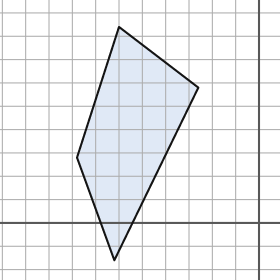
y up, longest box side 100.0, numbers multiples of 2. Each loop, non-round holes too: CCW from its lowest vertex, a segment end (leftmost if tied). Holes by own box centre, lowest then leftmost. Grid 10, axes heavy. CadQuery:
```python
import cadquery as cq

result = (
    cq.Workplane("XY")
    .moveTo(-62.0, -16.0)
    .lineTo(-26.0, 58.0)
    .lineTo(-60.0, 84.0)
    .lineTo(-78.0, 28.0)
    .close()
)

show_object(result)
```